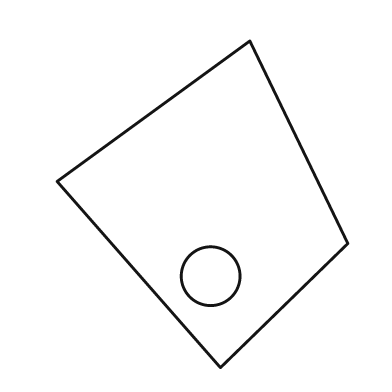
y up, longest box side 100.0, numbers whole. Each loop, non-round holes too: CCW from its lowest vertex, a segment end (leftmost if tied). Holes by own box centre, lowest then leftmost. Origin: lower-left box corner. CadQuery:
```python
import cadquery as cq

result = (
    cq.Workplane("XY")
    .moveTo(50.0, 0.0)
    .lineTo(89.0, 38.0)
    .lineTo(59.0, 100.0)
    .lineTo(0.0, 57.0)
    .close()
    .moveTo(47.0, 28.0)
    .circle(9.0)
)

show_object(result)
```